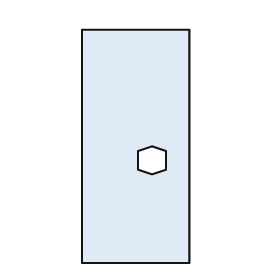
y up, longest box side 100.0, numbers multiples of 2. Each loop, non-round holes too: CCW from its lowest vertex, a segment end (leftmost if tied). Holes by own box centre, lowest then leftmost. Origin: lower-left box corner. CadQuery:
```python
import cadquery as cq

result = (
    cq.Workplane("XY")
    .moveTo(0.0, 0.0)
    .lineTo(46.0, 0.0)
    .lineTo(46.0, 100.0)
    .lineTo(0.0, 100.0)
    .close()
    .moveTo(30.0, 38.0)
    .lineTo(36.0, 40.0)
    .lineTo(36.0, 48.0)
    .lineTo(30.0, 50.0)
    .lineTo(24.0, 48.0)
    .lineTo(24.0, 40.0)
    .close()
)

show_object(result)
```